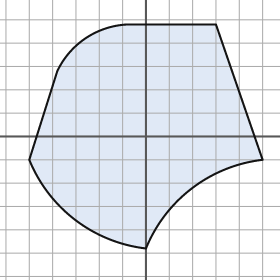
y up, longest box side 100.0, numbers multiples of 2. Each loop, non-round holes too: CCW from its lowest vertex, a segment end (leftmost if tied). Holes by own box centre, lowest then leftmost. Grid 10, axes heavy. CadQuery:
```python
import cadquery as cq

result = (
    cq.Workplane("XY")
    .moveTo(0.0, -48.0)
    .threePointArc((20.0, -22.0), (50.0, -10.0))
    .lineTo(30.0, 48.0)
    .lineTo(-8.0, 48.0)
    .threePointArc((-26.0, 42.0), (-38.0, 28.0))
    .lineTo(-50.0, -10.0)
    .threePointArc((-30.0, -36.0), (0.0, -48.0))
    .close()
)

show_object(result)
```